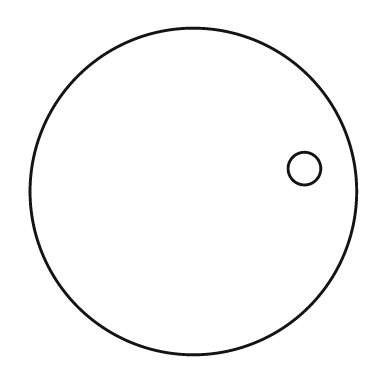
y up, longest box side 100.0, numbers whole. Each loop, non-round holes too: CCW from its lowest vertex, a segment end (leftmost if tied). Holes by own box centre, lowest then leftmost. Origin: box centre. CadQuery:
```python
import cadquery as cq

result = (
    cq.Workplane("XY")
    .moveTo(0.0, 0.0)
    .circle(50.0)
    .moveTo(34.0, 7.0)
    .circle(5.0)
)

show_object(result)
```